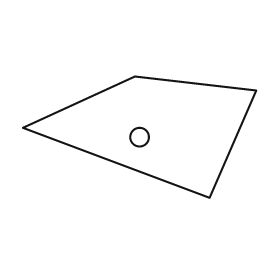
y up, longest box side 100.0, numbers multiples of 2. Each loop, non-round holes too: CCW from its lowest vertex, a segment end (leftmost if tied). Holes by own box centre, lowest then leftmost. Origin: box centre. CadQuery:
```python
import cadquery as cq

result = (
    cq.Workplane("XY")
    .moveTo(30.0, -26.0)
    .lineTo(50.0, 20.0)
    .lineTo(-2.0, 26.0)
    .lineTo(-50.0, 4.0)
    .close()
    .moveTo(0.0, 0.0)
    .circle(4.0)
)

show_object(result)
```